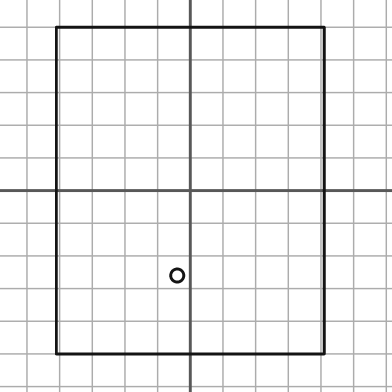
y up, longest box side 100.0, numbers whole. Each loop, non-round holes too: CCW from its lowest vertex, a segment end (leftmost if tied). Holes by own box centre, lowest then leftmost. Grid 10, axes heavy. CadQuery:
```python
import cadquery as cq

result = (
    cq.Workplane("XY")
    .moveTo(-41.0, -50.0)
    .lineTo(41.0, -50.0)
    .lineTo(41.0, 50.0)
    .lineTo(-41.0, 50.0)
    .close()
    .moveTo(-4.0, -26.0)
    .circle(2.0)
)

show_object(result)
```